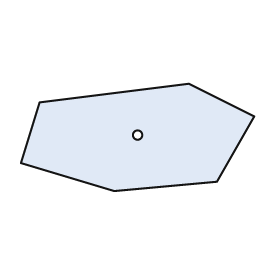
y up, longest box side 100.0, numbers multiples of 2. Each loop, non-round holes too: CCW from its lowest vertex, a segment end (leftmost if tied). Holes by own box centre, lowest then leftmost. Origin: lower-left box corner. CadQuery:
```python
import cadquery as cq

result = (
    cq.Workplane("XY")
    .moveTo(40.0, 0.0)
    .lineTo(84.0, 4.0)
    .lineTo(100.0, 32.0)
    .lineTo(72.0, 46.0)
    .lineTo(8.0, 38.0)
    .lineTo(0.0, 12.0)
    .close()
    .moveTo(50.0, 24.0)
    .circle(2.0)
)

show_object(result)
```